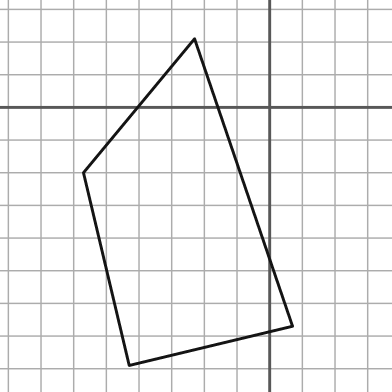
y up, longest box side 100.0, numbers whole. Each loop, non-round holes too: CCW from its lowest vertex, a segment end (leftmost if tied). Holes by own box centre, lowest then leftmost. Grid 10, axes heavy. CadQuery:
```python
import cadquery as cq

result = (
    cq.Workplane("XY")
    .moveTo(-43.0, -79.0)
    .lineTo(7.0, -67.0)
    .lineTo(-23.0, 21.0)
    .lineTo(-57.0, -20.0)
    .close()
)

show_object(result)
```